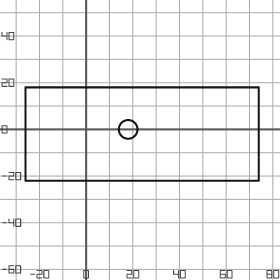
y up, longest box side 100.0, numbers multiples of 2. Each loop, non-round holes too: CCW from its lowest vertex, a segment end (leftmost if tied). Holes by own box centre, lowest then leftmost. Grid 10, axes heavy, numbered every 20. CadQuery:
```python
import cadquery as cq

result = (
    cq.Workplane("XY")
    .moveTo(-26.0, -22.0)
    .lineTo(74.0, -22.0)
    .lineTo(74.0, 18.0)
    .lineTo(-26.0, 18.0)
    .close()
    .moveTo(18.0, 0.0)
    .circle(4.0)
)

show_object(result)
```